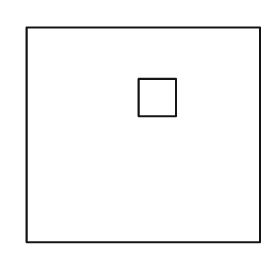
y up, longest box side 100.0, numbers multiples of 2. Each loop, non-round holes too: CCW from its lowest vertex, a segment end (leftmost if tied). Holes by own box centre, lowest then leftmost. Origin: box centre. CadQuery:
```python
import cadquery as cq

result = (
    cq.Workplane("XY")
    .moveTo(-50.0, -46.0)
    .lineTo(50.0, -46.0)
    .lineTo(50.0, 46.0)
    .lineTo(-50.0, 46.0)
    .close()
    .moveTo(-2.0, 8.0)
    .lineTo(14.0, 8.0)
    .lineTo(14.0, 24.0)
    .lineTo(-2.0, 24.0)
    .close()
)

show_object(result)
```